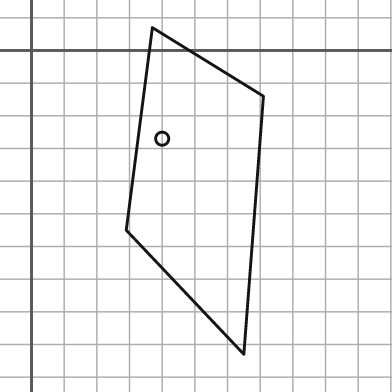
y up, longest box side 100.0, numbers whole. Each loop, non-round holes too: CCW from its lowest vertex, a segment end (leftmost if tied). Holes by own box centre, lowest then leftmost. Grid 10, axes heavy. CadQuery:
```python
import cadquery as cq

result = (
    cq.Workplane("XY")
    .moveTo(65.0, -93.0)
    .lineTo(71.0, -14.0)
    .lineTo(37.0, 7.0)
    .lineTo(29.0, -55.0)
    .close()
    .moveTo(40.0, -27.0)
    .circle(2.0)
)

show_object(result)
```